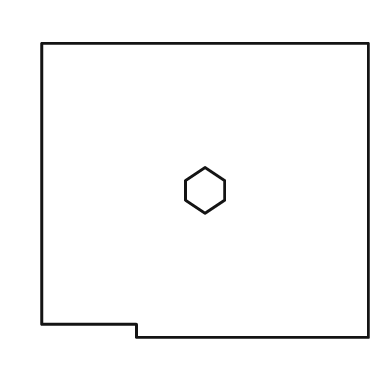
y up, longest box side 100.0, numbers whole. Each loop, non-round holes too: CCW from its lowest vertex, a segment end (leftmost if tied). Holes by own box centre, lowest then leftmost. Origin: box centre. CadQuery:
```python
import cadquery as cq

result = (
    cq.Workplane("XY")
    .moveTo(-21.0, -45.0)
    .lineTo(50.0, -45.0)
    .lineTo(50.0, 45.0)
    .lineTo(-50.0, 45.0)
    .lineTo(-50.0, -41.0)
    .lineTo(-21.0, -41.0)
    .close()
    .moveTo(0.0, -7.0)
    .lineTo(6.0, -3.0)
    .lineTo(6.0, 3.0)
    .lineTo(0.0, 7.0)
    .lineTo(-6.0, 3.0)
    .lineTo(-6.0, -3.0)
    .close()
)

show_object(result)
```